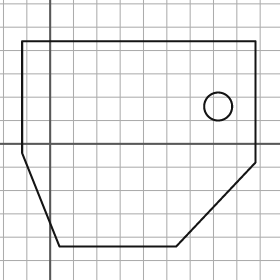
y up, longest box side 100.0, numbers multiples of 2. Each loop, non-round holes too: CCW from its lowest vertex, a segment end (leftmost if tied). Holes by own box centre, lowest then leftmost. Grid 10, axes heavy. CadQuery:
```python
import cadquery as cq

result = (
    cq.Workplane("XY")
    .moveTo(4.0, -44.0)
    .lineTo(54.0, -44.0)
    .lineTo(88.0, -8.0)
    .lineTo(88.0, 44.0)
    .lineTo(-12.0, 44.0)
    .lineTo(-12.0, -4.0)
    .close()
    .moveTo(72.0, 16.0)
    .circle(6.0)
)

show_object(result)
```